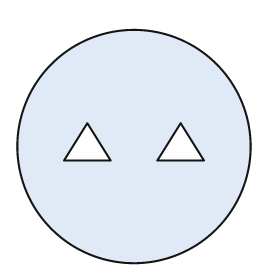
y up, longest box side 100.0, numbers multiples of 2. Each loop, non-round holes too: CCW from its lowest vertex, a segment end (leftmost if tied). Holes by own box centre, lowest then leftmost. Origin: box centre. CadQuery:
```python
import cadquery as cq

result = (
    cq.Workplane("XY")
    .moveTo(0.0, 0.0)
    .circle(50.0)
    .moveTo(-30.0, -6.0)
    .lineTo(-10.0, -6.0)
    .lineTo(-20.0, 10.0)
    .close()
    .moveTo(10.0, -6.0)
    .lineTo(30.0, -6.0)
    .lineTo(20.0, 10.0)
    .close()
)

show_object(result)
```